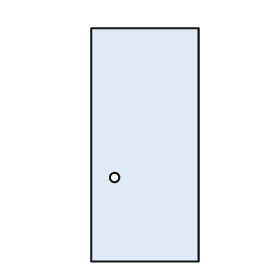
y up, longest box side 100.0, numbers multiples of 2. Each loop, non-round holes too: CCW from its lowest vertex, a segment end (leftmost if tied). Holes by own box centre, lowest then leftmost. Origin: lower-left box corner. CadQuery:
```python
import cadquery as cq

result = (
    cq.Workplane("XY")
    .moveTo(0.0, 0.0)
    .lineTo(46.0, 0.0)
    .lineTo(46.0, 100.0)
    .lineTo(0.0, 100.0)
    .close()
    .moveTo(10.0, 36.0)
    .circle(2.0)
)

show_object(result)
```